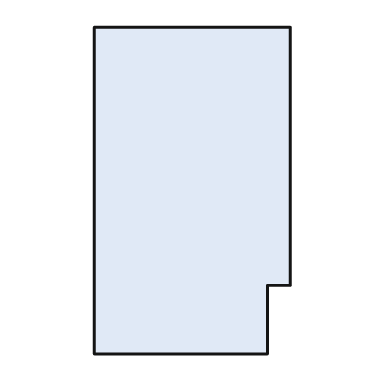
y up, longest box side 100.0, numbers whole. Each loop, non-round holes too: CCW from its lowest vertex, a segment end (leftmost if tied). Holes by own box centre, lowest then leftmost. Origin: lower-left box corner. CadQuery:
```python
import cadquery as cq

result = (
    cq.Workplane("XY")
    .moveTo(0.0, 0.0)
    .lineTo(53.0, 0.0)
    .lineTo(53.0, 21.0)
    .lineTo(60.0, 21.0)
    .lineTo(60.0, 100.0)
    .lineTo(0.0, 100.0)
    .close()
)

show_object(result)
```